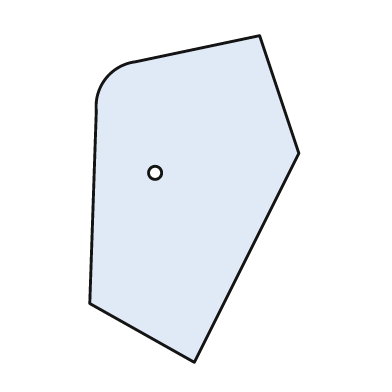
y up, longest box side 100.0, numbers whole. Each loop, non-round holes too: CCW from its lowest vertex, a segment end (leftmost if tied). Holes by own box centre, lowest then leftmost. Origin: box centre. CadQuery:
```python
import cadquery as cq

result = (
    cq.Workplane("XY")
    .moveTo(0.0, -50.0)
    .lineTo(32.0, 14.0)
    .lineTo(20.0, 50.0)
    .lineTo(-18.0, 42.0)
    .threePointArc((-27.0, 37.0), (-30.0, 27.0))
    .lineTo(-32.0, -32.0)
    .close()
    .moveTo(-12.0, 8.0)
    .circle(2.0)
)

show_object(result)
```